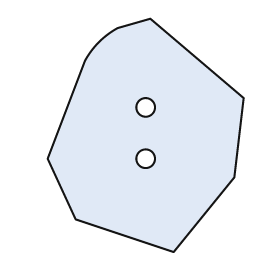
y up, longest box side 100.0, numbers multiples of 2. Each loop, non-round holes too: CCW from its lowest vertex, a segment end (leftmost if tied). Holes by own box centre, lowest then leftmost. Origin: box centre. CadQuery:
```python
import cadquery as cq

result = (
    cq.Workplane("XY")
    .moveTo(12.0, -50.0)
    .lineTo(38.0, -18.0)
    .lineTo(42.0, 16.0)
    .lineTo(2.0, 50.0)
    .lineTo(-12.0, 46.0)
    .threePointArc((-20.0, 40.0), (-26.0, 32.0))
    .lineTo(-42.0, -10.0)
    .lineTo(-30.0, -36.0)
    .close()
    .moveTo(0.0, -10.0)
    .circle(4.0)
    .moveTo(0.0, 12.0)
    .circle(4.0)
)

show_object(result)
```